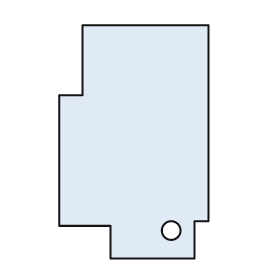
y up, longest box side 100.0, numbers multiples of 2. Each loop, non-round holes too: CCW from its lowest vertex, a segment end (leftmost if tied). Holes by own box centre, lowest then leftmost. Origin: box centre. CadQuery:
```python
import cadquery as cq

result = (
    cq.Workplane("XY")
    .moveTo(-10.0, -50.0)
    .lineTo(26.0, -50.0)
    .lineTo(26.0, -34.0)
    .lineTo(32.0, -34.0)
    .lineTo(32.0, 50.0)
    .lineTo(-22.0, 50.0)
    .lineTo(-22.0, 20.0)
    .lineTo(-32.0, 20.0)
    .lineTo(-32.0, -36.0)
    .lineTo(-10.0, -36.0)
    .close()
    .moveTo(16.0, -38.0)
    .circle(4.0)
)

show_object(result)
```